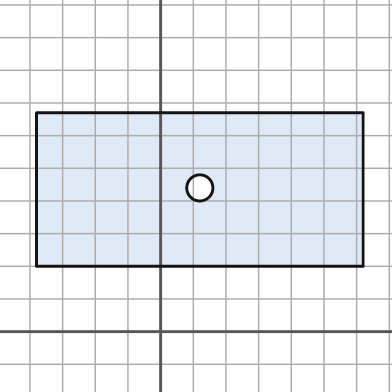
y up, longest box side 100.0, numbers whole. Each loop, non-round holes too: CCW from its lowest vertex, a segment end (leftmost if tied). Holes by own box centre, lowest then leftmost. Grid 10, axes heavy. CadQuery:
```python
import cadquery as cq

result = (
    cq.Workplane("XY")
    .moveTo(-38.0, 20.0)
    .lineTo(62.0, 20.0)
    .lineTo(62.0, 67.0)
    .lineTo(-38.0, 67.0)
    .close()
    .moveTo(12.0, 44.0)
    .circle(4.0)
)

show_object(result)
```